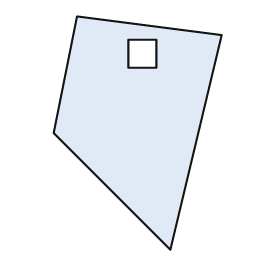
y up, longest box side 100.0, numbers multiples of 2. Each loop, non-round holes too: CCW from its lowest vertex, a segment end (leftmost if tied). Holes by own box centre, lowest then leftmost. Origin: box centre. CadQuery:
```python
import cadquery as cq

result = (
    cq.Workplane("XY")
    .moveTo(14.0, -50.0)
    .lineTo(36.0, 42.0)
    .lineTo(-26.0, 50.0)
    .lineTo(-36.0, 0.0)
    .close()
    .moveTo(-4.0, 28.0)
    .lineTo(8.0, 28.0)
    .lineTo(8.0, 40.0)
    .lineTo(-4.0, 40.0)
    .close()
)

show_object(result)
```